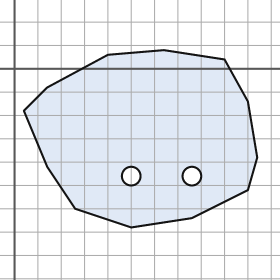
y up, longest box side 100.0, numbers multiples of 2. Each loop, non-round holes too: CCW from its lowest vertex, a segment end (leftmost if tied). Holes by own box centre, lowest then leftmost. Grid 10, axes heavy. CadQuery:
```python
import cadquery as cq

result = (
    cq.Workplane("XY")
    .moveTo(50.0, -68.0)
    .lineTo(76.0, -64.0)
    .lineTo(100.0, -52.0)
    .lineTo(104.0, -38.0)
    .lineTo(100.0, -14.0)
    .lineTo(90.0, 4.0)
    .lineTo(64.0, 8.0)
    .lineTo(40.0, 6.0)
    .lineTo(14.0, -8.0)
    .lineTo(4.0, -18.0)
    .lineTo(14.0, -42.0)
    .lineTo(26.0, -60.0)
    .close()
    .moveTo(50.0, -46.0)
    .circle(4.0)
    .moveTo(76.0, -46.0)
    .circle(4.0)
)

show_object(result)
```